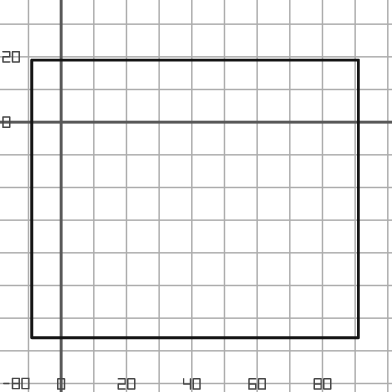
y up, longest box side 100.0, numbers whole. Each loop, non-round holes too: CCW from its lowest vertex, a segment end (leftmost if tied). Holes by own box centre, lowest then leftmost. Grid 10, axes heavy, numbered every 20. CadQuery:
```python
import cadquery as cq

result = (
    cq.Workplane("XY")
    .moveTo(-9.0, -66.0)
    .lineTo(91.0, -66.0)
    .lineTo(91.0, 19.0)
    .lineTo(-9.0, 19.0)
    .close()
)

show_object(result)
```